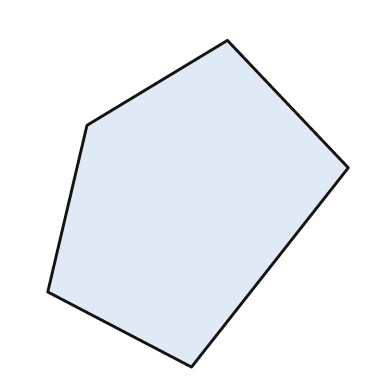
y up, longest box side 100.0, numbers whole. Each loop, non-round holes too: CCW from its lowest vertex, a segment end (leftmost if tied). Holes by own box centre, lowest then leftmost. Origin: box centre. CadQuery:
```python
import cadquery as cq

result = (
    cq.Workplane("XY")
    .moveTo(-2.0, -50.0)
    .lineTo(46.0, 11.0)
    .lineTo(9.0, 50.0)
    .lineTo(-34.0, 24.0)
    .lineTo(-46.0, -27.0)
    .close()
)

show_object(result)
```